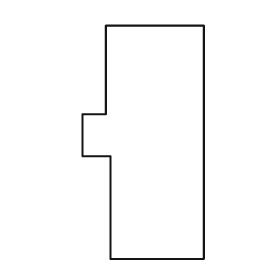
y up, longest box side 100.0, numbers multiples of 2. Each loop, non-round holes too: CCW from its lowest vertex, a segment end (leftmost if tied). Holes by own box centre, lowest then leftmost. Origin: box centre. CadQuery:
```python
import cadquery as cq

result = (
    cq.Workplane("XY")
    .moveTo(-14.0, -50.0)
    .lineTo(26.0, -50.0)
    .lineTo(26.0, 50.0)
    .lineTo(-16.0, 50.0)
    .lineTo(-16.0, 12.0)
    .lineTo(-26.0, 12.0)
    .lineTo(-26.0, -6.0)
    .lineTo(-14.0, -6.0)
    .close()
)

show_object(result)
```